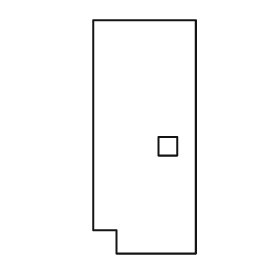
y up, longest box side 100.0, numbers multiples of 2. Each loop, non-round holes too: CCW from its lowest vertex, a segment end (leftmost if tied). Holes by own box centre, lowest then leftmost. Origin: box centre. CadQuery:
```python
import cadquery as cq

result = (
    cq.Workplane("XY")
    .moveTo(-12.0, -50.0)
    .lineTo(22.0, -50.0)
    .lineTo(22.0, 50.0)
    .lineTo(-22.0, 50.0)
    .lineTo(-22.0, -40.0)
    .lineTo(-12.0, -40.0)
    .close()
    .moveTo(6.0, -8.0)
    .lineTo(14.0, -8.0)
    .lineTo(14.0, 0.0)
    .lineTo(6.0, 0.0)
    .close()
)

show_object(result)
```